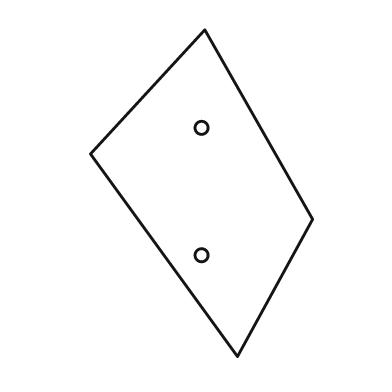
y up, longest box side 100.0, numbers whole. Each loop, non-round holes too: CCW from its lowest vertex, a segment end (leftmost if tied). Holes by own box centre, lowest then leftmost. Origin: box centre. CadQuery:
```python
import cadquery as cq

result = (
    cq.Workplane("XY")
    .moveTo(11.0, -50.0)
    .lineTo(34.0, -8.0)
    .lineTo(1.0, 50.0)
    .lineTo(-34.0, 12.0)
    .close()
    .moveTo(0.0, -19.0)
    .circle(2.0)
    .moveTo(0.0, 20.0)
    .circle(2.0)
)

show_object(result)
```